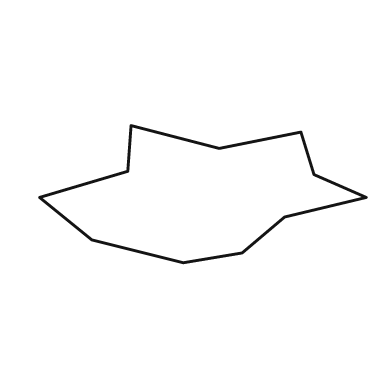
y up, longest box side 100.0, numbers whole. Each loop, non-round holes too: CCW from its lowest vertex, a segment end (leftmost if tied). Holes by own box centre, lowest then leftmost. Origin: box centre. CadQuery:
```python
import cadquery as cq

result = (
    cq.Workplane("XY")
    .moveTo(-6.0, -21.0)
    .lineTo(12.0, -18.0)
    .lineTo(25.0, -7.0)
    .lineTo(50.0, -1.0)
    .lineTo(34.0, 6.0)
    .lineTo(30.0, 19.0)
    .lineTo(5.0, 14.0)
    .lineTo(-22.0, 21.0)
    .lineTo(-23.0, 7.0)
    .lineTo(-50.0, -1.0)
    .lineTo(-34.0, -14.0)
    .close()
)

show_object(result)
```